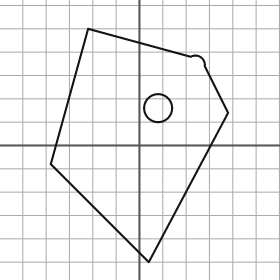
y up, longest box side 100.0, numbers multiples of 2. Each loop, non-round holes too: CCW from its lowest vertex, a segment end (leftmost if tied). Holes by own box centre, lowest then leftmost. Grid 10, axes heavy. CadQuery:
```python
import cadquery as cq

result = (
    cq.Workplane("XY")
    .moveTo(4.0, -50.0)
    .lineTo(38.0, 14.0)
    .lineTo(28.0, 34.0)
    .threePointArc((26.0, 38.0), (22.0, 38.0))
    .lineTo(-22.0, 50.0)
    .lineTo(-38.0, -8.0)
    .close()
    .moveTo(8.0, 16.0)
    .circle(6.0)
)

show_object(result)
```